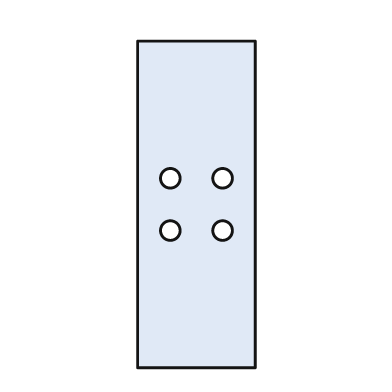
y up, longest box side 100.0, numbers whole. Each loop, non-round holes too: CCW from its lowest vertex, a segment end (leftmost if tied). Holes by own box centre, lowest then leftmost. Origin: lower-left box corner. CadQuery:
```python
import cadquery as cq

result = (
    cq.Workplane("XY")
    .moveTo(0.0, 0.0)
    .lineTo(36.0, 0.0)
    .lineTo(36.0, 100.0)
    .lineTo(0.0, 100.0)
    .close()
    .moveTo(10.0, 42.0)
    .circle(3.0)
    .moveTo(26.0, 42.0)
    .circle(3.0)
    .moveTo(10.0, 58.0)
    .circle(3.0)
    .moveTo(26.0, 58.0)
    .circle(3.0)
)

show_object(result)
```